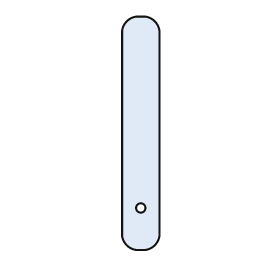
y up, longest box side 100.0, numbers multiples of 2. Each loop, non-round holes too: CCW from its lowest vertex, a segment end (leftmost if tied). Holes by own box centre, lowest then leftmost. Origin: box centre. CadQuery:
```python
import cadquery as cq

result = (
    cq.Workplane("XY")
    .moveTo(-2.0, -50.0)
    .lineTo(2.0, -50.0)
    .threePointArc((6.0, -48.0), (8.0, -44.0))
    .lineTo(8.0, 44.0)
    .threePointArc((6.0, 48.0), (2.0, 50.0))
    .lineTo(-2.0, 50.0)
    .threePointArc((-6.0, 48.0), (-8.0, 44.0))
    .lineTo(-8.0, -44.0)
    .threePointArc((-6.0, -48.0), (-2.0, -50.0))
    .close()
    .moveTo(0.0, -32.0)
    .circle(2.0)
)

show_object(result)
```